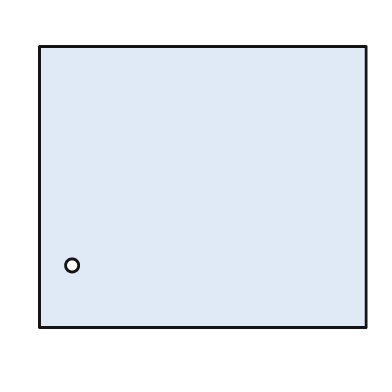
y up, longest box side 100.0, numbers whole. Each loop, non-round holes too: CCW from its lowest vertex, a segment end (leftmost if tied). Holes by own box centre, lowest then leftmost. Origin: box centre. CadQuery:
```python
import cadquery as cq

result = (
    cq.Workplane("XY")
    .moveTo(-50.0, -43.0)
    .lineTo(50.0, -43.0)
    .lineTo(50.0, 43.0)
    .lineTo(-50.0, 43.0)
    .close()
    .moveTo(-40.0, -24.0)
    .circle(2.0)
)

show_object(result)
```